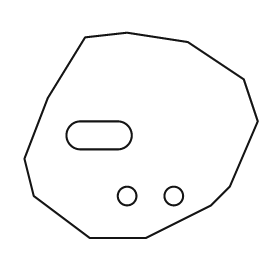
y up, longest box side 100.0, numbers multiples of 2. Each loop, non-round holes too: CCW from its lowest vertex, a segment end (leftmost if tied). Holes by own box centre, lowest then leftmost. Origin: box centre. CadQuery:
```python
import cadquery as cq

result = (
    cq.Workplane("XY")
    .moveTo(-22.0, -44.0)
    .lineTo(2.0, -44.0)
    .lineTo(30.0, -30.0)
    .lineTo(38.0, -22.0)
    .lineTo(50.0, 6.0)
    .lineTo(44.0, 24.0)
    .lineTo(20.0, 40.0)
    .lineTo(-6.0, 44.0)
    .lineTo(-24.0, 42.0)
    .lineTo(-40.0, 16.0)
    .lineTo(-50.0, -10.0)
    .lineTo(-46.0, -26.0)
    .close()
    .moveTo(-6.0, -26.0)
    .circle(4.0)
    .moveTo(14.0, -26.0)
    .circle(4.0)
    .moveTo(-26.0, -6.0)
    .lineTo(-10.0, -6.0)
    .threePointArc((-4.0, 0.0), (-10.0, 6.0))
    .lineTo(-26.0, 6.0)
    .threePointArc((-32.0, 0.0), (-26.0, -6.0))
    .close()
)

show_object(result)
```